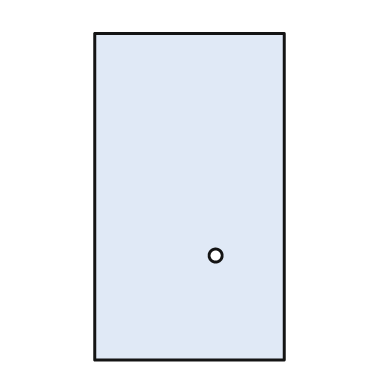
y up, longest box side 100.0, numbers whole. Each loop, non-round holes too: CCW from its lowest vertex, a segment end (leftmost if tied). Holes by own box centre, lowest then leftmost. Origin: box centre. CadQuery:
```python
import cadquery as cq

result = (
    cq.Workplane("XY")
    .moveTo(-29.0, -50.0)
    .lineTo(29.0, -50.0)
    .lineTo(29.0, 50.0)
    .lineTo(-29.0, 50.0)
    .close()
    .moveTo(8.0, -18.0)
    .circle(2.0)
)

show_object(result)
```